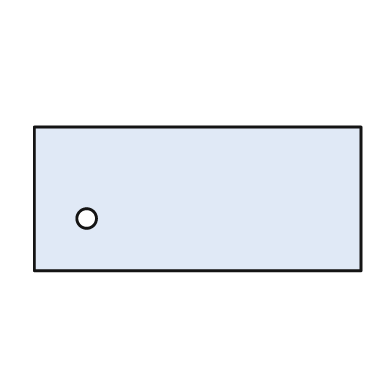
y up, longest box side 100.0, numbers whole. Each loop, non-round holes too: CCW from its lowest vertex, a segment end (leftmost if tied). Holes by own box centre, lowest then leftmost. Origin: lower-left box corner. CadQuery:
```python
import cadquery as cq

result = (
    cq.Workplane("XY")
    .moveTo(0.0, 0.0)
    .lineTo(100.0, 0.0)
    .lineTo(100.0, 44.0)
    .lineTo(0.0, 44.0)
    .close()
    .moveTo(16.0, 16.0)
    .circle(3.0)
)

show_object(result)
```